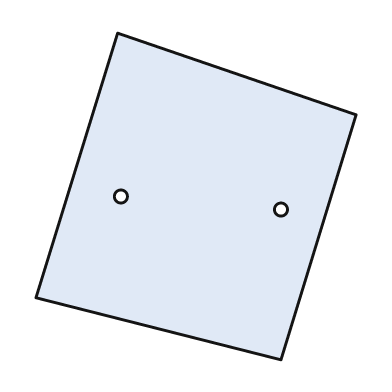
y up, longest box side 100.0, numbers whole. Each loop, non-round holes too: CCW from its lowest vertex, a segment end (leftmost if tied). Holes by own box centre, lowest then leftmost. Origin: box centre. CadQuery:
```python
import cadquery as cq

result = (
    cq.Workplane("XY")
    .moveTo(26.0, -50.0)
    .lineTo(49.0, 25.0)
    .lineTo(-24.0, 50.0)
    .lineTo(-49.0, -31.0)
    .close()
    .moveTo(26.0, -4.0)
    .circle(2.0)
    .moveTo(-23.0, 0.0)
    .circle(2.0)
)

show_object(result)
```